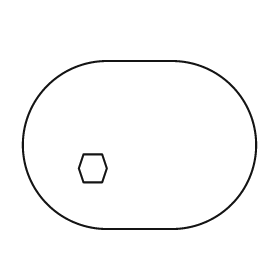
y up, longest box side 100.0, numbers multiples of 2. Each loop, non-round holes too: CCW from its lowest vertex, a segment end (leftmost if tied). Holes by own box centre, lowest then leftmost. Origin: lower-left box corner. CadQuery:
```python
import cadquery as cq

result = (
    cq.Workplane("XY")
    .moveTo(36.0, 0.0)
    .lineTo(64.0, 0.0)
    .threePointArc((100.0, 36.0), (64.0, 72.0))
    .lineTo(36.0, 72.0)
    .threePointArc((0.0, 36.0), (36.0, 0.0))
    .close()
    .moveTo(26.0, 20.0)
    .lineTo(34.0, 20.0)
    .lineTo(36.0, 26.0)
    .lineTo(34.0, 32.0)
    .lineTo(26.0, 32.0)
    .lineTo(24.0, 26.0)
    .close()
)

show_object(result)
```